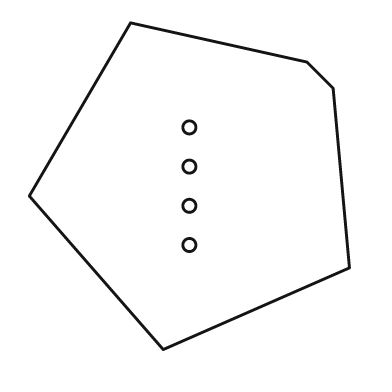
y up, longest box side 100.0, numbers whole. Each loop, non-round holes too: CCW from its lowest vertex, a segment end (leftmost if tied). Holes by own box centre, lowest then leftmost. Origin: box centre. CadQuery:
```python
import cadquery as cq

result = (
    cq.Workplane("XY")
    .moveTo(-8.0, -50.0)
    .lineTo(49.0, -25.0)
    .lineTo(44.0, 30.0)
    .lineTo(36.0, 38.0)
    .lineTo(-18.0, 50.0)
    .lineTo(-49.0, -3.0)
    .close()
    .moveTo(0.0, -18.0)
    .circle(2.0)
    .moveTo(0.0, -6.0)
    .circle(2.0)
    .moveTo(0.0, 6.0)
    .circle(2.0)
    .moveTo(0.0, 18.0)
    .circle(2.0)
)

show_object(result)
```